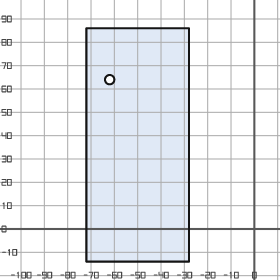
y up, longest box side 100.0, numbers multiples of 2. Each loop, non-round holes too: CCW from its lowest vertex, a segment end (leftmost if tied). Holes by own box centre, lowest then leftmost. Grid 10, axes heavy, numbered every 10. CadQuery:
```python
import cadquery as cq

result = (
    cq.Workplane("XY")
    .moveTo(-72.0, -14.0)
    .lineTo(-28.0, -14.0)
    .lineTo(-28.0, 86.0)
    .lineTo(-72.0, 86.0)
    .close()
    .moveTo(-62.0, 64.0)
    .circle(2.0)
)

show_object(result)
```